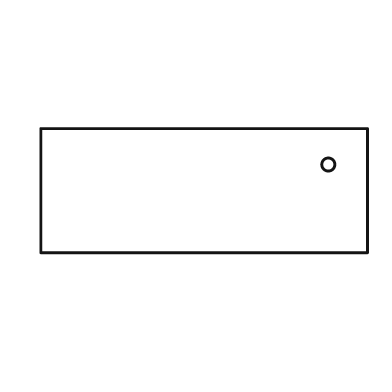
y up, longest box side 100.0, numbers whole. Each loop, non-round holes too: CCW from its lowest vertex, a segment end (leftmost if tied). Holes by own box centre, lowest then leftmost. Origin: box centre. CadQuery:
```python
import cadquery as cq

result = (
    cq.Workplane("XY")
    .moveTo(-50.0, -19.0)
    .lineTo(50.0, -19.0)
    .lineTo(50.0, 19.0)
    .lineTo(-50.0, 19.0)
    .close()
    .moveTo(38.0, 8.0)
    .circle(2.0)
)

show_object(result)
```